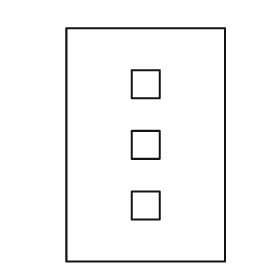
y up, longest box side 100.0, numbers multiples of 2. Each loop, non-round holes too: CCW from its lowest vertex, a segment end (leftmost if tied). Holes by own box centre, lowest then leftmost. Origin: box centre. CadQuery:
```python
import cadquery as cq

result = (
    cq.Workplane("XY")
    .moveTo(-34.0, -50.0)
    .lineTo(34.0, -50.0)
    .lineTo(34.0, 50.0)
    .lineTo(-34.0, 50.0)
    .close()
    .moveTo(-6.0, -32.0)
    .lineTo(6.0, -32.0)
    .lineTo(6.0, -20.0)
    .lineTo(-6.0, -20.0)
    .close()
    .moveTo(-6.0, -6.0)
    .lineTo(6.0, -6.0)
    .lineTo(6.0, 6.0)
    .lineTo(-6.0, 6.0)
    .close()
    .moveTo(-6.0, 20.0)
    .lineTo(6.0, 20.0)
    .lineTo(6.0, 32.0)
    .lineTo(-6.0, 32.0)
    .close()
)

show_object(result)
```